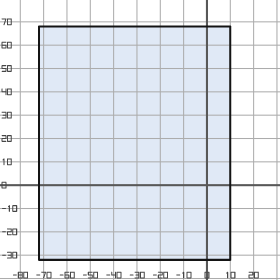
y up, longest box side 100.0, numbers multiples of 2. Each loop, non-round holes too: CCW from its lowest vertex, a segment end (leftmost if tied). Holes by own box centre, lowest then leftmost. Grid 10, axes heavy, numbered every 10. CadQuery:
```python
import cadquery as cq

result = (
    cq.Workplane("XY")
    .moveTo(-72.0, -32.0)
    .lineTo(10.0, -32.0)
    .lineTo(10.0, 68.0)
    .lineTo(-72.0, 68.0)
    .close()
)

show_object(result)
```